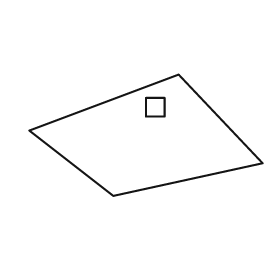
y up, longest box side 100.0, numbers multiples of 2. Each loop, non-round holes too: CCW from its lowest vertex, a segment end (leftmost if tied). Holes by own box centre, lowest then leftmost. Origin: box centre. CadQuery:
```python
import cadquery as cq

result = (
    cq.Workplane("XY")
    .moveTo(-14.0, -26.0)
    .lineTo(50.0, -12.0)
    .lineTo(14.0, 26.0)
    .lineTo(-50.0, 2.0)
    .close()
    .moveTo(0.0, 8.0)
    .lineTo(8.0, 8.0)
    .lineTo(8.0, 16.0)
    .lineTo(0.0, 16.0)
    .close()
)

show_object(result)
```